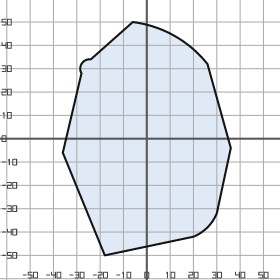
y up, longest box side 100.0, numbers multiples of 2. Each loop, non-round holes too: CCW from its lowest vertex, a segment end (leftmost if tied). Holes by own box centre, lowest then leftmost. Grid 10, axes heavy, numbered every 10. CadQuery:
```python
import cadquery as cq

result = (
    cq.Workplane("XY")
    .moveTo(-18.0, -50.0)
    .lineTo(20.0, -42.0)
    .threePointArc((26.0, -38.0), (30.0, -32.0))
    .lineTo(36.0, -4.0)
    .lineTo(26.0, 32.0)
    .threePointArc((12.0, 44.0), (-6.0, 50.0))
    .lineTo(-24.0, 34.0)
    .threePointArc((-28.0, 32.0), (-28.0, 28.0))
    .lineTo(-36.0, -6.0)
    .close()
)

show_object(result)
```